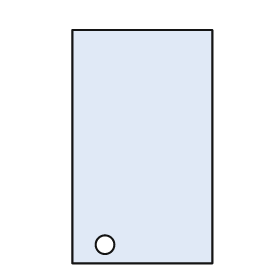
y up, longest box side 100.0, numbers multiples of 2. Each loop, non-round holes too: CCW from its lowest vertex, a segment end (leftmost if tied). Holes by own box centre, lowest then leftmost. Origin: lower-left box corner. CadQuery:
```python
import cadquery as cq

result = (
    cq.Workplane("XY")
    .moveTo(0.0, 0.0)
    .lineTo(60.0, 0.0)
    .lineTo(60.0, 100.0)
    .lineTo(0.0, 100.0)
    .close()
    .moveTo(14.0, 8.0)
    .circle(4.0)
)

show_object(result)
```